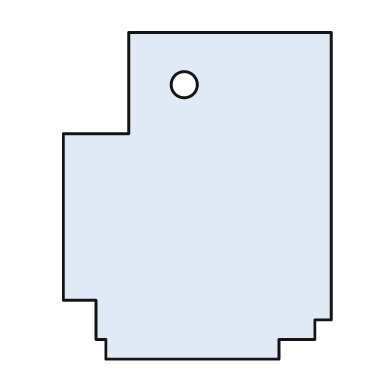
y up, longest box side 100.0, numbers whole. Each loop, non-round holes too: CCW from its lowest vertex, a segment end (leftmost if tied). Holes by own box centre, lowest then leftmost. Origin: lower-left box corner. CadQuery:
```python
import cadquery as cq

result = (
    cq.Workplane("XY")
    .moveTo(13.0, 0.0)
    .lineTo(66.0, 0.0)
    .lineTo(66.0, 6.0)
    .lineTo(77.0, 6.0)
    .lineTo(77.0, 12.0)
    .lineTo(82.0, 12.0)
    .lineTo(82.0, 100.0)
    .lineTo(20.0, 100.0)
    .lineTo(20.0, 69.0)
    .lineTo(0.0, 69.0)
    .lineTo(0.0, 18.0)
    .lineTo(10.0, 18.0)
    .lineTo(10.0, 6.0)
    .lineTo(13.0, 6.0)
    .close()
    .moveTo(37.0, 84.0)
    .circle(4.0)
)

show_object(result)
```